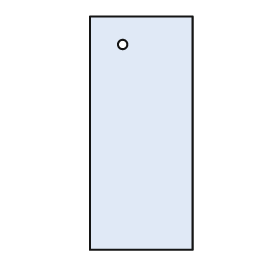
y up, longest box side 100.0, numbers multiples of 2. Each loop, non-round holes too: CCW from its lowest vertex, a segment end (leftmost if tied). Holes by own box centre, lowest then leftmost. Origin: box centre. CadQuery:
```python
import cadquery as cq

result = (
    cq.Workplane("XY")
    .moveTo(-22.0, -50.0)
    .lineTo(22.0, -50.0)
    .lineTo(22.0, 50.0)
    .lineTo(-22.0, 50.0)
    .close()
    .moveTo(-8.0, 38.0)
    .circle(2.0)
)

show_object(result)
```